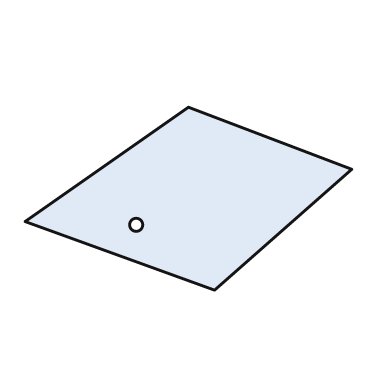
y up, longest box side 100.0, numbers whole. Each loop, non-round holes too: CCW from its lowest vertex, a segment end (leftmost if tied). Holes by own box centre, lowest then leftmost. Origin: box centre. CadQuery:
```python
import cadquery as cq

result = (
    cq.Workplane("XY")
    .moveTo(8.0, -28.0)
    .lineTo(50.0, 9.0)
    .lineTo(0.0, 28.0)
    .lineTo(-50.0, -7.0)
    .close()
    .moveTo(-16.0, -8.0)
    .circle(2.0)
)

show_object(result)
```